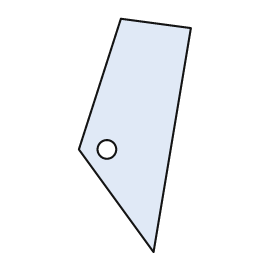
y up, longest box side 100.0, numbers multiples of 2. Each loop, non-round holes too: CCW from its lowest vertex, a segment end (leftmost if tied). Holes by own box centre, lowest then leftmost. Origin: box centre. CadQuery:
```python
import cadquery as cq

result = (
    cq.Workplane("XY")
    .moveTo(8.0, -50.0)
    .lineTo(24.0, 46.0)
    .lineTo(-6.0, 50.0)
    .lineTo(-24.0, -6.0)
    .close()
    .moveTo(-12.0, -6.0)
    .circle(4.0)
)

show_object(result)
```